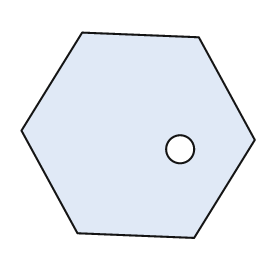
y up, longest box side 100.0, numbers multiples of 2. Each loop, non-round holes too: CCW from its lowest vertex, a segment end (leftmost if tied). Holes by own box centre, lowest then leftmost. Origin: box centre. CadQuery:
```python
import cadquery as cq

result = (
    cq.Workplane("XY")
    .moveTo(24.0, -44.0)
    .lineTo(50.0, -2.0)
    .lineTo(26.0, 42.0)
    .lineTo(-24.0, 44.0)
    .lineTo(-50.0, 2.0)
    .lineTo(-26.0, -42.0)
    .close()
    .moveTo(18.0, -6.0)
    .circle(6.0)
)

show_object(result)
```